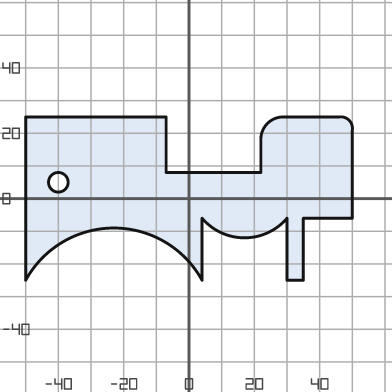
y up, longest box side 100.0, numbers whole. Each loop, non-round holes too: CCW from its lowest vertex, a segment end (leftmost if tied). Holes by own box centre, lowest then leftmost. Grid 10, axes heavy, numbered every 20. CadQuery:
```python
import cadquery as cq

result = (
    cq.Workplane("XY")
    .moveTo(-50.0, -25.0)
    .threePointArc((-23.0, -9.0), (4.0, -25.0))
    .lineTo(4.0, -6.0)
    .threePointArc((17.0, -12.0), (30.0, -6.0))
    .lineTo(30.0, -25.0)
    .lineTo(35.0, -25.0)
    .lineTo(35.0, -6.0)
    .lineTo(50.0, -6.0)
    .lineTo(50.0, 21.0)
    .threePointArc((49.0, 24.0), (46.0, 25.0))
    .lineTo(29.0, 25.0)
    .threePointArc((24.0, 23.0), (22.0, 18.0))
    .lineTo(22.0, 8.0)
    .lineTo(-7.0, 8.0)
    .lineTo(-7.0, 25.0)
    .lineTo(-50.0, 25.0)
    .close()
    .moveTo(-40.0, 5.0)
    .circle(3.0)
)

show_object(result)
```